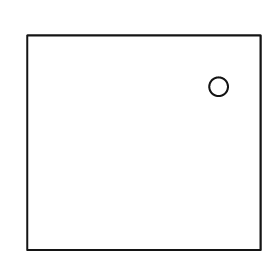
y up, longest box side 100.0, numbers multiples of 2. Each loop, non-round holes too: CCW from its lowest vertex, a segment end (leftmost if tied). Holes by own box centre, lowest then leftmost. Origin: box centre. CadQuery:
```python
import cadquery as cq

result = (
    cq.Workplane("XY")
    .moveTo(-50.0, -46.0)
    .lineTo(50.0, -46.0)
    .lineTo(50.0, 46.0)
    .lineTo(-50.0, 46.0)
    .close()
    .moveTo(32.0, 24.0)
    .circle(4.0)
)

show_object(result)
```